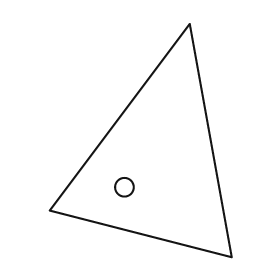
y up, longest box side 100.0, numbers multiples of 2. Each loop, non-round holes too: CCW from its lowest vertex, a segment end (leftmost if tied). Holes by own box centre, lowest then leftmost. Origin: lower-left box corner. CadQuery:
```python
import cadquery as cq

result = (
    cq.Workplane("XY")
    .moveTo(78.0, 0.0)
    .lineTo(60.0, 100.0)
    .lineTo(0.0, 20.0)
    .close()
    .moveTo(32.0, 30.0)
    .circle(4.0)
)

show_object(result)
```